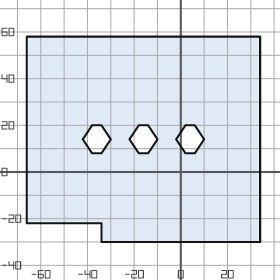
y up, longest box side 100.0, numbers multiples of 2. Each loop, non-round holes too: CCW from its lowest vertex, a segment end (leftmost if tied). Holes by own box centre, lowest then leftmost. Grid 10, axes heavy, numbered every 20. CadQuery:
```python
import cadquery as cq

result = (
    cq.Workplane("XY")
    .moveTo(-34.0, -30.0)
    .lineTo(34.0, -30.0)
    .lineTo(34.0, 58.0)
    .lineTo(-66.0, 58.0)
    .lineTo(-66.0, -22.0)
    .lineTo(-34.0, -22.0)
    .close()
    .moveTo(-38.0, 8.0)
    .lineTo(-34.0, 8.0)
    .lineTo(-30.0, 14.0)
    .lineTo(-34.0, 20.0)
    .lineTo(-38.0, 20.0)
    .lineTo(-42.0, 14.0)
    .close()
    .moveTo(-18.0, 8.0)
    .lineTo(-14.0, 8.0)
    .lineTo(-10.0, 14.0)
    .lineTo(-14.0, 20.0)
    .lineTo(-18.0, 20.0)
    .lineTo(-22.0, 14.0)
    .close()
    .moveTo(2.0, 8.0)
    .lineTo(6.0, 8.0)
    .lineTo(10.0, 14.0)
    .lineTo(6.0, 20.0)
    .lineTo(2.0, 20.0)
    .lineTo(-2.0, 14.0)
    .close()
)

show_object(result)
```